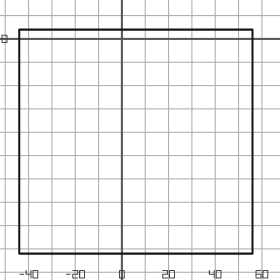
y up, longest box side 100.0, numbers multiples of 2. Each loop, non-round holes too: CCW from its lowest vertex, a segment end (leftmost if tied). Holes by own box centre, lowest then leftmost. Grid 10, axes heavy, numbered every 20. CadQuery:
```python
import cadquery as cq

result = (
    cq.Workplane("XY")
    .moveTo(-44.0, -92.0)
    .lineTo(56.0, -92.0)
    .lineTo(56.0, 4.0)
    .lineTo(-44.0, 4.0)
    .close()
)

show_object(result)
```